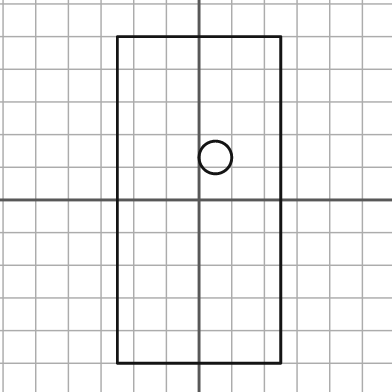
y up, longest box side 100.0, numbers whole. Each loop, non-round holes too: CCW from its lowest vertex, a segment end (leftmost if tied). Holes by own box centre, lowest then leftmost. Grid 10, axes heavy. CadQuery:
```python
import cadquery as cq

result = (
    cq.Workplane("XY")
    .moveTo(-25.0, -50.0)
    .lineTo(25.0, -50.0)
    .lineTo(25.0, 50.0)
    .lineTo(-25.0, 50.0)
    .close()
    .moveTo(5.0, 13.0)
    .circle(5.0)
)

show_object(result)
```